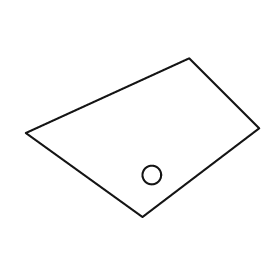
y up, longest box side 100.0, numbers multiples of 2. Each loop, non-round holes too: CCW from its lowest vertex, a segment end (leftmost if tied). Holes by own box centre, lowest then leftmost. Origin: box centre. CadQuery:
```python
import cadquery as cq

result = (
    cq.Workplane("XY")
    .moveTo(0.0, -34.0)
    .lineTo(50.0, 4.0)
    .lineTo(20.0, 34.0)
    .lineTo(-50.0, 2.0)
    .close()
    .moveTo(4.0, -16.0)
    .circle(4.0)
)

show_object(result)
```